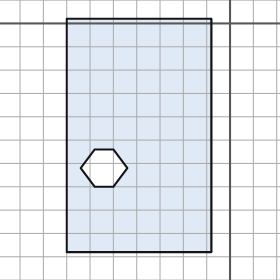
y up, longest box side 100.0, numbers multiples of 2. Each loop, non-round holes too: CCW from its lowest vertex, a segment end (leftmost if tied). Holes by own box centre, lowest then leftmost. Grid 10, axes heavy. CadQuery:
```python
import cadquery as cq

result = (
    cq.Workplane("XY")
    .moveTo(-70.0, -98.0)
    .lineTo(-8.0, -98.0)
    .lineTo(-8.0, 2.0)
    .lineTo(-70.0, 2.0)
    .close()
    .moveTo(-58.0, -70.0)
    .lineTo(-50.0, -70.0)
    .lineTo(-44.0, -62.0)
    .lineTo(-50.0, -54.0)
    .lineTo(-58.0, -54.0)
    .lineTo(-64.0, -62.0)
    .close()
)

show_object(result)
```